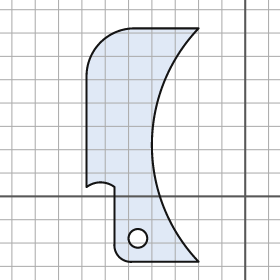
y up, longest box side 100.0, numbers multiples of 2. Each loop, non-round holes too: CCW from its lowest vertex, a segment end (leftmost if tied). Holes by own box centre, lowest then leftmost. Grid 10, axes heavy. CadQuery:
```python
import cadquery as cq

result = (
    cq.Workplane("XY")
    .moveTo(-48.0, -28.0)
    .lineTo(-20.0, -28.0)
    .threePointArc((-40.0, 22.0), (-20.0, 72.0))
    .lineTo(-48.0, 72.0)
    .threePointArc((-62.0, 66.0), (-68.0, 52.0))
    .lineTo(-68.0, 4.0)
    .threePointArc((-62.0, 6.0), (-56.0, 4.0))
    .lineTo(-56.0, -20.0)
    .threePointArc((-54.0, -26.0), (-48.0, -28.0))
    .close()
    .moveTo(-46.0, -18.0)
    .circle(4.0)
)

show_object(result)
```